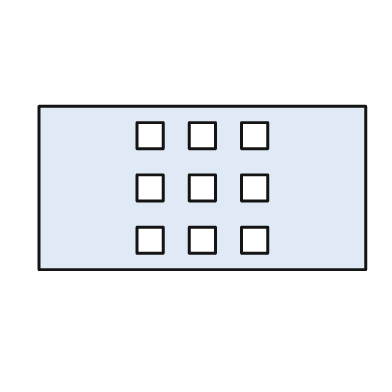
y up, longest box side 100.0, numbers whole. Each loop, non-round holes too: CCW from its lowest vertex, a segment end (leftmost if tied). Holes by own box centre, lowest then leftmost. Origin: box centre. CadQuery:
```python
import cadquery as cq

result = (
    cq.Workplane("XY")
    .moveTo(-50.0, -25.0)
    .lineTo(50.0, -25.0)
    .lineTo(50.0, 25.0)
    .lineTo(-50.0, 25.0)
    .close()
    .moveTo(-20.0, -20.0)
    .lineTo(-12.0, -20.0)
    .lineTo(-12.0, -12.0)
    .lineTo(-20.0, -12.0)
    .close()
    .moveTo(-4.0, -20.0)
    .lineTo(4.0, -20.0)
    .lineTo(4.0, -12.0)
    .lineTo(-4.0, -12.0)
    .close()
    .moveTo(12.0, -20.0)
    .lineTo(20.0, -20.0)
    .lineTo(20.0, -12.0)
    .lineTo(12.0, -12.0)
    .close()
    .moveTo(-20.0, -4.0)
    .lineTo(-12.0, -4.0)
    .lineTo(-12.0, 4.0)
    .lineTo(-20.0, 4.0)
    .close()
    .moveTo(-4.0, -4.0)
    .lineTo(4.0, -4.0)
    .lineTo(4.0, 4.0)
    .lineTo(-4.0, 4.0)
    .close()
    .moveTo(12.0, -4.0)
    .lineTo(20.0, -4.0)
    .lineTo(20.0, 4.0)
    .lineTo(12.0, 4.0)
    .close()
    .moveTo(-20.0, 12.0)
    .lineTo(-12.0, 12.0)
    .lineTo(-12.0, 20.0)
    .lineTo(-20.0, 20.0)
    .close()
    .moveTo(-4.0, 12.0)
    .lineTo(4.0, 12.0)
    .lineTo(4.0, 20.0)
    .lineTo(-4.0, 20.0)
    .close()
    .moveTo(12.0, 12.0)
    .lineTo(20.0, 12.0)
    .lineTo(20.0, 20.0)
    .lineTo(12.0, 20.0)
    .close()
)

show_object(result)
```